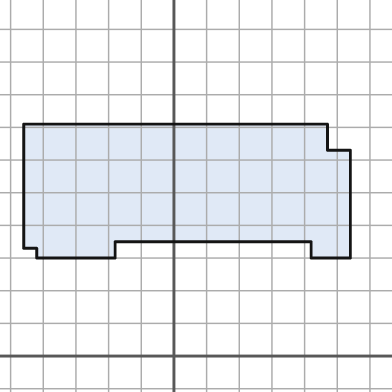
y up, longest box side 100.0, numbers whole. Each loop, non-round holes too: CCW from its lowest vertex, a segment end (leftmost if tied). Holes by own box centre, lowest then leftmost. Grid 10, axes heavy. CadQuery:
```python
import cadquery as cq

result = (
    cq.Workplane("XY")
    .moveTo(-42.0, 30.0)
    .lineTo(-18.0, 30.0)
    .lineTo(-18.0, 35.0)
    .lineTo(42.0, 35.0)
    .lineTo(42.0, 30.0)
    .lineTo(54.0, 30.0)
    .lineTo(54.0, 63.0)
    .lineTo(47.0, 63.0)
    .lineTo(47.0, 71.0)
    .lineTo(-46.0, 71.0)
    .lineTo(-46.0, 33.0)
    .lineTo(-42.0, 33.0)
    .close()
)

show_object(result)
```